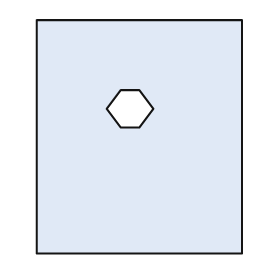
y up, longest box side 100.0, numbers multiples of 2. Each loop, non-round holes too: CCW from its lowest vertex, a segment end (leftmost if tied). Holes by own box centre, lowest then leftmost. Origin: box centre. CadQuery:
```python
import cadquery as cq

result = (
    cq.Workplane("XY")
    .moveTo(-44.0, -50.0)
    .lineTo(44.0, -50.0)
    .lineTo(44.0, 50.0)
    .lineTo(-44.0, 50.0)
    .close()
    .moveTo(-8.0, 4.0)
    .lineTo(0.0, 4.0)
    .lineTo(6.0, 12.0)
    .lineTo(0.0, 20.0)
    .lineTo(-8.0, 20.0)
    .lineTo(-14.0, 12.0)
    .close()
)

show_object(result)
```